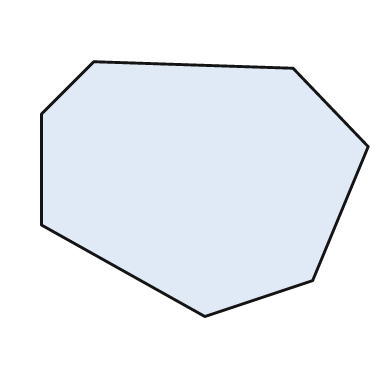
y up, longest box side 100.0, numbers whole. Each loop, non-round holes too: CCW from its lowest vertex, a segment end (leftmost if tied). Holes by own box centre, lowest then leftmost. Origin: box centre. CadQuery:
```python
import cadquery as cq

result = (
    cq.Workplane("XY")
    .moveTo(0.0, -39.0)
    .lineTo(33.0, -28.0)
    .lineTo(50.0, 13.0)
    .lineTo(27.0, 37.0)
    .lineTo(-34.0, 39.0)
    .lineTo(-50.0, 23.0)
    .lineTo(-50.0, -11.0)
    .close()
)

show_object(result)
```